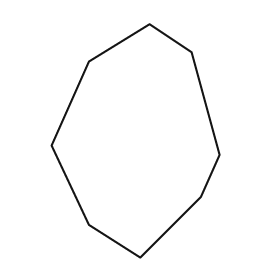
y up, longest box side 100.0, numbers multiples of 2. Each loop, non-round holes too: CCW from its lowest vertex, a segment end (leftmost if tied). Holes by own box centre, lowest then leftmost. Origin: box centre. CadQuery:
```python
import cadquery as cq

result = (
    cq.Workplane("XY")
    .moveTo(2.0, -50.0)
    .lineTo(28.0, -24.0)
    .lineTo(36.0, -6.0)
    .lineTo(24.0, 38.0)
    .lineTo(6.0, 50.0)
    .lineTo(-20.0, 34.0)
    .lineTo(-36.0, -2.0)
    .lineTo(-20.0, -36.0)
    .close()
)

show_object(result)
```